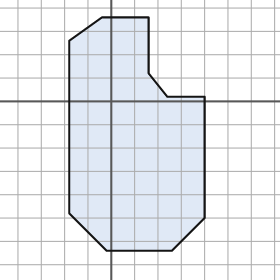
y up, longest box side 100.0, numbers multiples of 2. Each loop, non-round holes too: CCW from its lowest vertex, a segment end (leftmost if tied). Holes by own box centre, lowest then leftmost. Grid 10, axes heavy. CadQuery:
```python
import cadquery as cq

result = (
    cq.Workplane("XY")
    .moveTo(-2.0, -64.0)
    .lineTo(26.0, -64.0)
    .lineTo(40.0, -50.0)
    .lineTo(40.0, 2.0)
    .lineTo(24.0, 2.0)
    .lineTo(16.0, 12.0)
    .lineTo(16.0, 36.0)
    .lineTo(-4.0, 36.0)
    .lineTo(-18.0, 26.0)
    .lineTo(-18.0, -48.0)
    .close()
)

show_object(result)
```